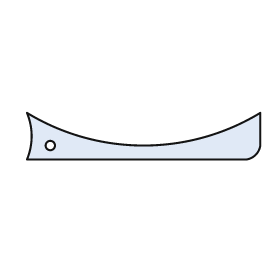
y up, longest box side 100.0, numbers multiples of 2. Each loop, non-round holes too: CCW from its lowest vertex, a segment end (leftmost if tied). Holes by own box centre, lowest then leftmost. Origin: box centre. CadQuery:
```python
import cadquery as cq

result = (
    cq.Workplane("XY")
    .moveTo(-50.0, -10.0)
    .lineTo(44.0, -10.0)
    .threePointArc((48.0, -8.0), (50.0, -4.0))
    .lineTo(50.0, 10.0)
    .threePointArc((0.0, -4.0), (-50.0, 10.0))
    .threePointArc((-48.0, 0.0), (-50.0, -10.0))
    .close()
    .moveTo(-40.0, -4.0)
    .circle(2.0)
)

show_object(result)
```